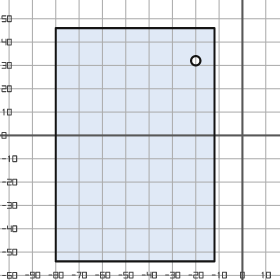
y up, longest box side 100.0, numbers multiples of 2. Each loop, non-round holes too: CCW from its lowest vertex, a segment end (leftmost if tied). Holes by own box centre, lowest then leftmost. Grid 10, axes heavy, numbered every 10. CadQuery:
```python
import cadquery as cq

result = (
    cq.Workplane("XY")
    .moveTo(-80.0, -54.0)
    .lineTo(-12.0, -54.0)
    .lineTo(-12.0, 46.0)
    .lineTo(-80.0, 46.0)
    .close()
    .moveTo(-20.0, 32.0)
    .circle(2.0)
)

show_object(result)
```